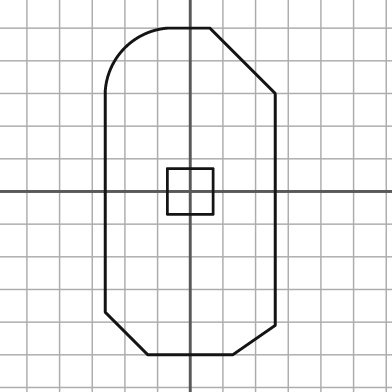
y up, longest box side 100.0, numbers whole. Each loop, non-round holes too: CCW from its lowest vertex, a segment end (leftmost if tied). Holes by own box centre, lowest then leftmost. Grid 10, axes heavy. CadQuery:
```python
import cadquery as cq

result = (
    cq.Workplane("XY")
    .moveTo(-13.0, -50.0)
    .lineTo(13.0, -50.0)
    .lineTo(26.0, -41.0)
    .lineTo(26.0, 30.0)
    .lineTo(6.0, 50.0)
    .lineTo(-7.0, 50.0)
    .threePointArc((-20.0, 44.0), (-26.0, 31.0))
    .lineTo(-26.0, -37.0)
    .close()
    .moveTo(-7.0, -7.0)
    .lineTo(7.0, -7.0)
    .lineTo(7.0, 7.0)
    .lineTo(-7.0, 7.0)
    .close()
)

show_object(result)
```